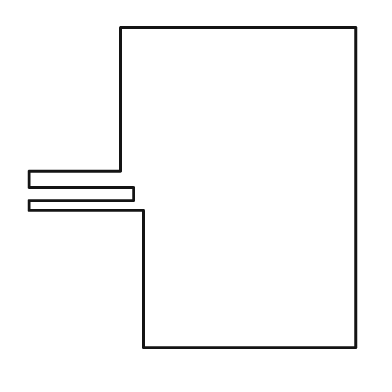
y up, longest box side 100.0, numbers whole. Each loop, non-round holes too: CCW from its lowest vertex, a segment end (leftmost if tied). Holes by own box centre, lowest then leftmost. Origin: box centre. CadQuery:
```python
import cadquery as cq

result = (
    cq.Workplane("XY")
    .moveTo(-15.0, -49.0)
    .lineTo(50.0, -49.0)
    .lineTo(50.0, 49.0)
    .lineTo(-22.0, 49.0)
    .lineTo(-22.0, 5.0)
    .lineTo(-50.0, 5.0)
    .lineTo(-50.0, 0.0)
    .lineTo(-18.0, 0.0)
    .lineTo(-18.0, -4.0)
    .lineTo(-50.0, -4.0)
    .lineTo(-50.0, -7.0)
    .lineTo(-15.0, -7.0)
    .close()
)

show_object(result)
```